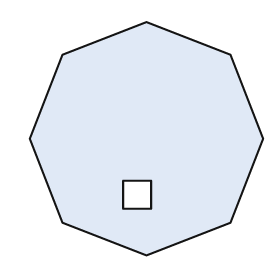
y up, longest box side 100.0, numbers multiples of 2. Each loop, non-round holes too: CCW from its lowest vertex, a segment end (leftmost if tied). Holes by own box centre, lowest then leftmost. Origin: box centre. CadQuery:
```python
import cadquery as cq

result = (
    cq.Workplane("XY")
    .moveTo(0.0, -50.0)
    .lineTo(36.0, -36.0)
    .lineTo(50.0, 0.0)
    .lineTo(36.0, 36.0)
    .lineTo(0.0, 50.0)
    .lineTo(-36.0, 36.0)
    .lineTo(-50.0, 0.0)
    .lineTo(-36.0, -36.0)
    .close()
    .moveTo(-10.0, -30.0)
    .lineTo(2.0, -30.0)
    .lineTo(2.0, -18.0)
    .lineTo(-10.0, -18.0)
    .close()
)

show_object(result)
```